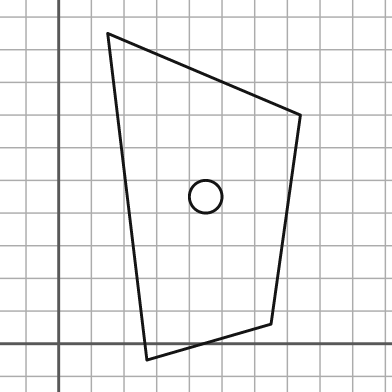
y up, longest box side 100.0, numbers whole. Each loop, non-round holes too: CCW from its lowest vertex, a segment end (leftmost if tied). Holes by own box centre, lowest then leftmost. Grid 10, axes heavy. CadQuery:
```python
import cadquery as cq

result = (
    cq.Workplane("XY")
    .moveTo(27.0, -5.0)
    .lineTo(65.0, 6.0)
    .lineTo(74.0, 70.0)
    .lineTo(15.0, 95.0)
    .close()
    .moveTo(45.0, 45.0)
    .circle(5.0)
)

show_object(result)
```